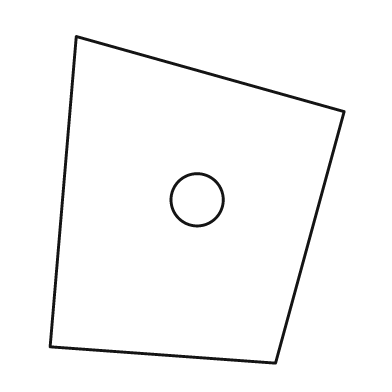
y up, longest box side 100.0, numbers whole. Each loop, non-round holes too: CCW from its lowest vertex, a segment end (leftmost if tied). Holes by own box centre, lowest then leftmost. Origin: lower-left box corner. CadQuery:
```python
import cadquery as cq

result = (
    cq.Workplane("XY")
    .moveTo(69.0, 0.0)
    .lineTo(90.0, 77.0)
    .lineTo(8.0, 100.0)
    .lineTo(0.0, 5.0)
    .close()
    .moveTo(45.0, 50.0)
    .circle(8.0)
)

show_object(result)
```